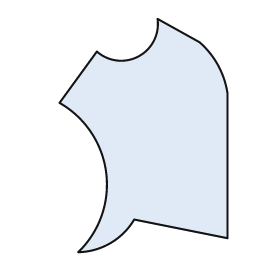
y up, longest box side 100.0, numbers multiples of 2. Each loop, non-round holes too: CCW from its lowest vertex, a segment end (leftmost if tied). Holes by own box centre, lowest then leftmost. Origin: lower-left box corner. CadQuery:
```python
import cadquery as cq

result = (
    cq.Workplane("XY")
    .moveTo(8.0, 0.0)
    .threePointArc((22.0, 4.0), (32.0, 14.0))
    .lineTo(72.0, 6.0)
    .lineTo(72.0, 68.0)
    .threePointArc((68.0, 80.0), (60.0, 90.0))
    .lineTo(42.0, 100.0)
    .threePointArc((34.0, 84.0), (16.0, 86.0))
    .lineTo(0.0, 64.0)
    .threePointArc((20.0, 34.0), (8.0, 0.0))
    .close()
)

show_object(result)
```